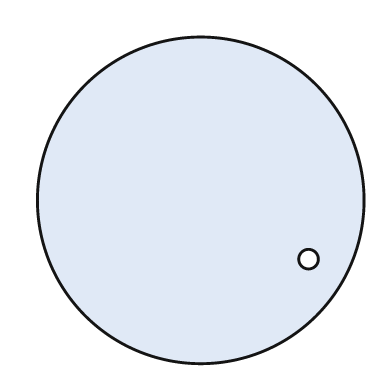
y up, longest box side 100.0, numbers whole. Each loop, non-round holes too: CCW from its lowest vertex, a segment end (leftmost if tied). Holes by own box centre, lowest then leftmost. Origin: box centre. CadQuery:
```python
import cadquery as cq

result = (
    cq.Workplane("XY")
    .moveTo(0.0, 0.0)
    .circle(50.0)
    .moveTo(33.0, -18.0)
    .circle(3.0)
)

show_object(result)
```